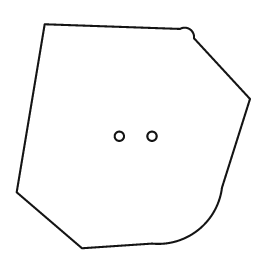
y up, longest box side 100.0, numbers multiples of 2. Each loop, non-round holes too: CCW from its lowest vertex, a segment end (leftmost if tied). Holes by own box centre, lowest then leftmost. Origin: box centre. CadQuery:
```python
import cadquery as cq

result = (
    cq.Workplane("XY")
    .moveTo(-22.0, -48.0)
    .lineTo(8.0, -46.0)
    .threePointArc((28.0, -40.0), (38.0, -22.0))
    .lineTo(50.0, 16.0)
    .lineTo(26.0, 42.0)
    .threePointArc((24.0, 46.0), (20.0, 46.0))
    .lineTo(-38.0, 48.0)
    .lineTo(-50.0, -24.0)
    .close()
    .moveTo(-6.0, 0.0)
    .circle(2.0)
    .moveTo(8.0, 0.0)
    .circle(2.0)
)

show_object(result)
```